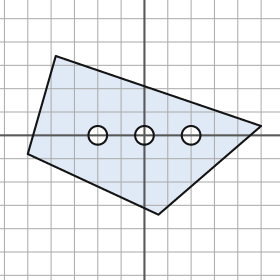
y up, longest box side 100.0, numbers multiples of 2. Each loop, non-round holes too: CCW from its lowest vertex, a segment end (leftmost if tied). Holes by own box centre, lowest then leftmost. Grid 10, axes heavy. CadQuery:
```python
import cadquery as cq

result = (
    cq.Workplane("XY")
    .moveTo(6.0, -34.0)
    .lineTo(50.0, 4.0)
    .lineTo(-38.0, 34.0)
    .lineTo(-50.0, -8.0)
    .close()
    .moveTo(-20.0, 0.0)
    .circle(4.0)
    .moveTo(0.0, 0.0)
    .circle(4.0)
    .moveTo(20.0, 0.0)
    .circle(4.0)
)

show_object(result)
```